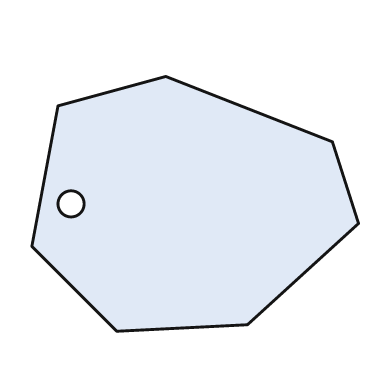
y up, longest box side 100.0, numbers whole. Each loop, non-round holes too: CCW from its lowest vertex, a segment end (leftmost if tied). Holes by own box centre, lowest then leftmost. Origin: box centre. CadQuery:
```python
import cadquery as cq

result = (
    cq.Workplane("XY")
    .moveTo(-24.0, -39.0)
    .lineTo(16.0, -37.0)
    .lineTo(50.0, -6.0)
    .lineTo(42.0, 19.0)
    .lineTo(-9.0, 39.0)
    .lineTo(-42.0, 30.0)
    .lineTo(-50.0, -13.0)
    .close()
    .moveTo(-38.0, 0.0)
    .circle(4.0)
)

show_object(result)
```